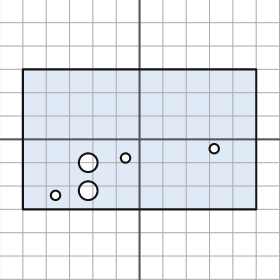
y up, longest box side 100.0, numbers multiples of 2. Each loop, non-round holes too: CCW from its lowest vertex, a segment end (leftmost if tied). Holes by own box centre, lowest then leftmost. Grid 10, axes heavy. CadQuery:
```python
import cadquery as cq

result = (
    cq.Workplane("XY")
    .moveTo(-50.0, -30.0)
    .lineTo(50.0, -30.0)
    .lineTo(50.0, 30.0)
    .lineTo(-50.0, 30.0)
    .close()
    .moveTo(-36.0, -24.0)
    .circle(2.0)
    .moveTo(-22.0, -22.0)
    .circle(4.0)
    .moveTo(-22.0, -10.0)
    .circle(4.0)
    .moveTo(-6.0, -8.0)
    .circle(2.0)
    .moveTo(32.0, -4.0)
    .circle(2.0)
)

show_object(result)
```